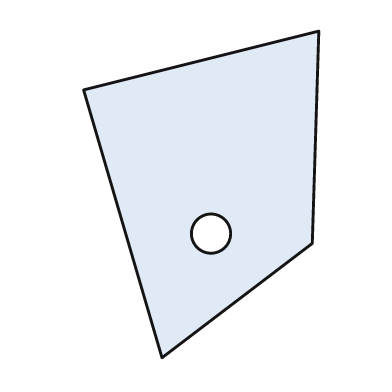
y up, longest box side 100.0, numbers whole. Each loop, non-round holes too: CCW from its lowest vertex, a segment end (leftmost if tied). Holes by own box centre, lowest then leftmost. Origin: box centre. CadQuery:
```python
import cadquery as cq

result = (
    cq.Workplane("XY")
    .moveTo(-12.0, -50.0)
    .lineTo(34.0, -15.0)
    .lineTo(36.0, 50.0)
    .lineTo(-36.0, 32.0)
    .close()
    .moveTo(3.0, -12.0)
    .circle(6.0)
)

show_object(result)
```